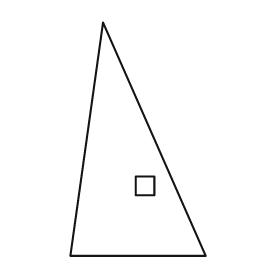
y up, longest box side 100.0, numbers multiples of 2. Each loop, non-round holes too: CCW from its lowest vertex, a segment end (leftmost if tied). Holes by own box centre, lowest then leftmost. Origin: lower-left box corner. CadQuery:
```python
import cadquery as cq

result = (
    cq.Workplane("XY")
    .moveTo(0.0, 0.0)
    .lineTo(58.0, 0.0)
    .lineTo(14.0, 100.0)
    .close()
    .moveTo(28.0, 26.0)
    .lineTo(36.0, 26.0)
    .lineTo(36.0, 34.0)
    .lineTo(28.0, 34.0)
    .close()
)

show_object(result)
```